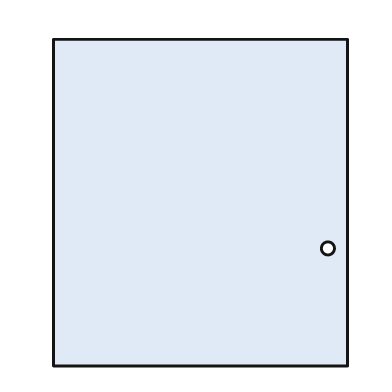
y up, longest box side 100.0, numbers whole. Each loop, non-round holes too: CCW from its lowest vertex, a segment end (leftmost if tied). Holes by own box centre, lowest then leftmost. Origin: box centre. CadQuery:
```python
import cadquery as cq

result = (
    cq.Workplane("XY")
    .moveTo(-45.0, -50.0)
    .lineTo(45.0, -50.0)
    .lineTo(45.0, 50.0)
    .lineTo(-45.0, 50.0)
    .close()
    .moveTo(39.0, -14.0)
    .circle(2.0)
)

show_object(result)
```